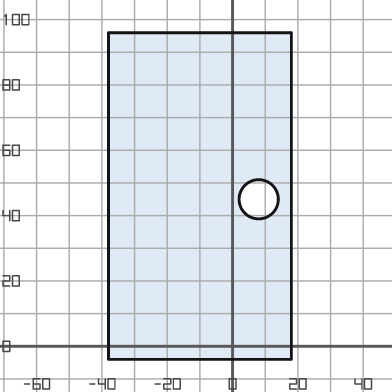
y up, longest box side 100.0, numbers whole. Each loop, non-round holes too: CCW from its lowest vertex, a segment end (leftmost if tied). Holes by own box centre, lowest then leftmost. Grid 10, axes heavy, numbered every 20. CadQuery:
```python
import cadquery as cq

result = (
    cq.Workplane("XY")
    .moveTo(-38.0, -4.0)
    .lineTo(18.0, -4.0)
    .lineTo(18.0, 96.0)
    .lineTo(-38.0, 96.0)
    .close()
    .moveTo(8.0, 45.0)
    .circle(6.0)
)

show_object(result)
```